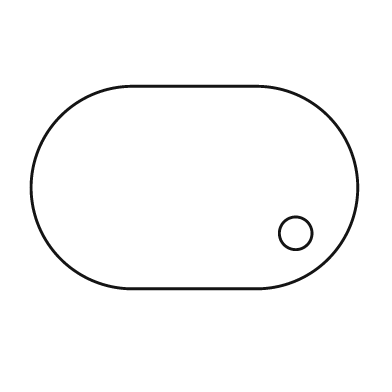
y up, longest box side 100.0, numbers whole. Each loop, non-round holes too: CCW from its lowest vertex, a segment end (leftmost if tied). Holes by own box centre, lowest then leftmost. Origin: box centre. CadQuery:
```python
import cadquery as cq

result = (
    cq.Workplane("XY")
    .moveTo(-19.0, -31.0)
    .lineTo(19.0, -31.0)
    .threePointArc((50.0, 0.0), (19.0, 31.0))
    .lineTo(-19.0, 31.0)
    .threePointArc((-50.0, 0.0), (-19.0, -31.0))
    .close()
    .moveTo(31.0, -14.0)
    .circle(5.0)
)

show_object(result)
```